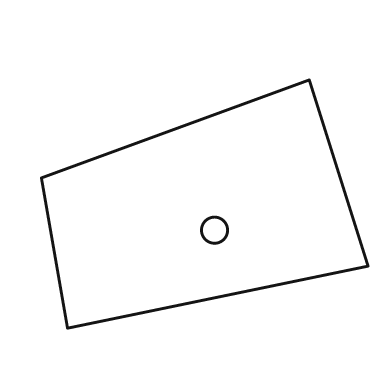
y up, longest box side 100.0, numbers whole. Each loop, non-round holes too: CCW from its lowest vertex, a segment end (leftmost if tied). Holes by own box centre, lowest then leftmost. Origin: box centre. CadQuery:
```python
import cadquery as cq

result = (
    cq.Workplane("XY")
    .moveTo(-42.0, -38.0)
    .lineTo(50.0, -19.0)
    .lineTo(32.0, 38.0)
    .lineTo(-50.0, 8.0)
    .close()
    .moveTo(3.0, -8.0)
    .circle(4.0)
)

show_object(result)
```